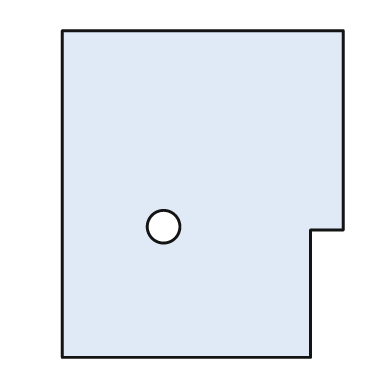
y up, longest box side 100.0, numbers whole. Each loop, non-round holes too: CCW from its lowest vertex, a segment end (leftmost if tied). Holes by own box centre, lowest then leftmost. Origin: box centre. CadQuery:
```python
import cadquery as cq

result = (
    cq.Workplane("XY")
    .moveTo(-43.0, -50.0)
    .lineTo(33.0, -50.0)
    .lineTo(33.0, -11.0)
    .lineTo(43.0, -11.0)
    .lineTo(43.0, 50.0)
    .lineTo(-43.0, 50.0)
    .close()
    .moveTo(-12.0, -10.0)
    .circle(5.0)
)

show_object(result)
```